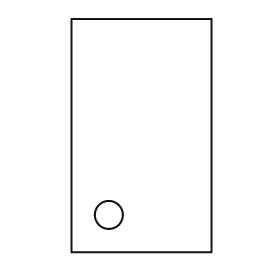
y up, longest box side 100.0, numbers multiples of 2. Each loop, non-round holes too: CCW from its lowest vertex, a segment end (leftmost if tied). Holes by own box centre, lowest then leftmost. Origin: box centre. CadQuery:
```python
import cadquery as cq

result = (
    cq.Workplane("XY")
    .moveTo(-30.0, -50.0)
    .lineTo(30.0, -50.0)
    .lineTo(30.0, 50.0)
    .lineTo(-30.0, 50.0)
    .close()
    .moveTo(-14.0, -34.0)
    .circle(6.0)
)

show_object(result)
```